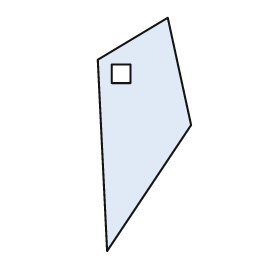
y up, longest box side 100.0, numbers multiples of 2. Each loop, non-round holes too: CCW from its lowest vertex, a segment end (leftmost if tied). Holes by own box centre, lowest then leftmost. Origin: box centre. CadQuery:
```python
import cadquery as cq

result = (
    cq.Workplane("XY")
    .moveTo(-16.0, -50.0)
    .lineTo(20.0, 4.0)
    .lineTo(10.0, 50.0)
    .lineTo(-20.0, 32.0)
    .close()
    .moveTo(-14.0, 22.0)
    .lineTo(-6.0, 22.0)
    .lineTo(-6.0, 30.0)
    .lineTo(-14.0, 30.0)
    .close()
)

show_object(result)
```